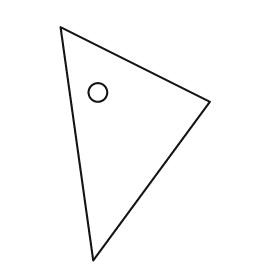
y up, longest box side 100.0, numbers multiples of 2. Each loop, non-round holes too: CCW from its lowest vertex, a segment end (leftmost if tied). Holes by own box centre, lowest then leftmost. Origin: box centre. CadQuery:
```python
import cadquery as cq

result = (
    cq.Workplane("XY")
    .moveTo(-18.0, -50.0)
    .lineTo(32.0, 18.0)
    .lineTo(-32.0, 50.0)
    .close()
    .moveTo(-16.0, 22.0)
    .circle(4.0)
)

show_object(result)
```